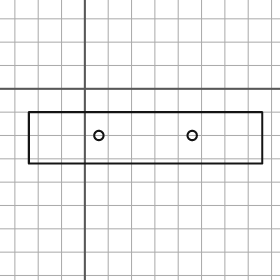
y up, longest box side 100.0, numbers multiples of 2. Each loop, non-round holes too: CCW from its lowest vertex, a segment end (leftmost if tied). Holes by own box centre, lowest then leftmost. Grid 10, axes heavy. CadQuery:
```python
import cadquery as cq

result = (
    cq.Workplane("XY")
    .moveTo(-24.0, -32.0)
    .lineTo(76.0, -32.0)
    .lineTo(76.0, -10.0)
    .lineTo(-24.0, -10.0)
    .close()
    .moveTo(6.0, -20.0)
    .circle(2.0)
    .moveTo(46.0, -20.0)
    .circle(2.0)
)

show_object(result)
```